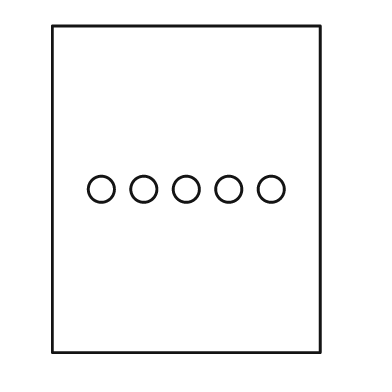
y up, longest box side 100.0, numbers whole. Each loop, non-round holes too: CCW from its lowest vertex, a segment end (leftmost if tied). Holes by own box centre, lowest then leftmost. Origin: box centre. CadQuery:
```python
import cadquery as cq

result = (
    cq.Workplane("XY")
    .moveTo(-41.0, -50.0)
    .lineTo(41.0, -50.0)
    .lineTo(41.0, 50.0)
    .lineTo(-41.0, 50.0)
    .close()
    .moveTo(-26.0, 0.0)
    .circle(4.0)
    .moveTo(-13.0, 0.0)
    .circle(4.0)
    .moveTo(0.0, 0.0)
    .circle(4.0)
    .moveTo(13.0, 0.0)
    .circle(4.0)
    .moveTo(26.0, 0.0)
    .circle(4.0)
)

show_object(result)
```